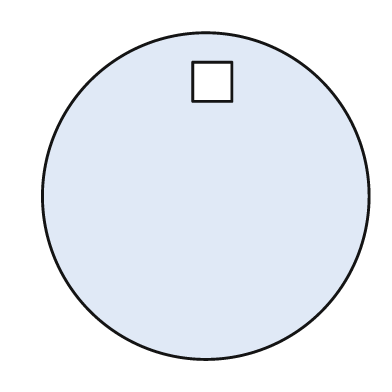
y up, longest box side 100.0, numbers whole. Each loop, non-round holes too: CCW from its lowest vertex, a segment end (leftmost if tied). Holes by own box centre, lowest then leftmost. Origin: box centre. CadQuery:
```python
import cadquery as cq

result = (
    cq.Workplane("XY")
    .moveTo(0.0, 0.0)
    .circle(50.0)
    .moveTo(-4.0, 29.0)
    .lineTo(8.0, 29.0)
    .lineTo(8.0, 41.0)
    .lineTo(-4.0, 41.0)
    .close()
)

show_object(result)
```